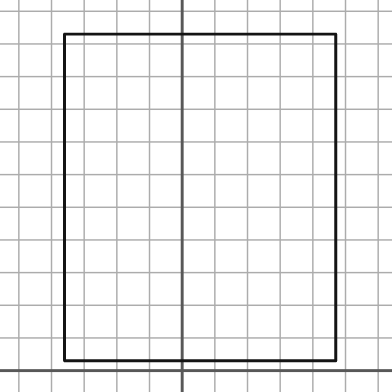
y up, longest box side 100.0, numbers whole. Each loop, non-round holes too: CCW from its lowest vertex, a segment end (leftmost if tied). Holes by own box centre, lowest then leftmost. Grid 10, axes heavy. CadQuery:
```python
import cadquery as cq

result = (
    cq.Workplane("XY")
    .moveTo(-36.0, 3.0)
    .lineTo(47.0, 3.0)
    .lineTo(47.0, 103.0)
    .lineTo(-36.0, 103.0)
    .close()
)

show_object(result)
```